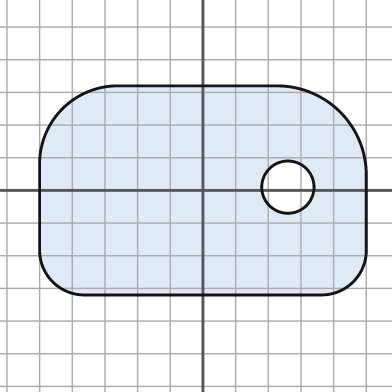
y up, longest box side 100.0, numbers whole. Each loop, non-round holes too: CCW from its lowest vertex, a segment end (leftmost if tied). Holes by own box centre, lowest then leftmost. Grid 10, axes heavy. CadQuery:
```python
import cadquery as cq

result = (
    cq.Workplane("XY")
    .moveTo(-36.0, -32.0)
    .lineTo(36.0, -32.0)
    .threePointArc((46.0, -28.0), (50.0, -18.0))
    .lineTo(50.0, 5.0)
    .threePointArc((42.0, 24.0), (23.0, 32.0))
    .lineTo(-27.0, 32.0)
    .threePointArc((-43.0, 25.0), (-50.0, 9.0))
    .lineTo(-50.0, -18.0)
    .threePointArc((-46.0, -28.0), (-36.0, -32.0))
    .close()
    .moveTo(26.0, 1.0)
    .circle(8.0)
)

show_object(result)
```